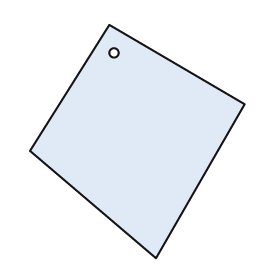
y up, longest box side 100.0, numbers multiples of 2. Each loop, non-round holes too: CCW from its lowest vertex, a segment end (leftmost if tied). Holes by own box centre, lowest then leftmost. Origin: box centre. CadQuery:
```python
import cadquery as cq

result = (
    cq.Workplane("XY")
    .moveTo(8.0, -50.0)
    .lineTo(46.0, 16.0)
    .lineTo(-12.0, 50.0)
    .lineTo(-46.0, -4.0)
    .close()
    .moveTo(-10.0, 38.0)
    .circle(2.0)
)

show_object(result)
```